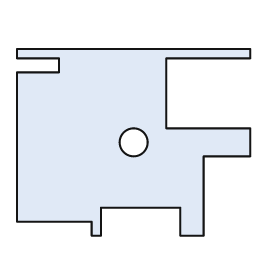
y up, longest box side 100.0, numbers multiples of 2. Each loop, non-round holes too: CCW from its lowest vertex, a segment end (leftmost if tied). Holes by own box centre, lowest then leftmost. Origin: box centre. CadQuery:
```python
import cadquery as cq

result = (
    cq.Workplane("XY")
    .moveTo(-18.0, -40.0)
    .lineTo(-14.0, -40.0)
    .lineTo(-14.0, -28.0)
    .lineTo(20.0, -28.0)
    .lineTo(20.0, -40.0)
    .lineTo(30.0, -40.0)
    .lineTo(30.0, -6.0)
    .lineTo(50.0, -6.0)
    .lineTo(50.0, 6.0)
    .lineTo(14.0, 6.0)
    .lineTo(14.0, 36.0)
    .lineTo(50.0, 36.0)
    .lineTo(50.0, 40.0)
    .lineTo(-50.0, 40.0)
    .lineTo(-50.0, 36.0)
    .lineTo(-32.0, 36.0)
    .lineTo(-32.0, 30.0)
    .lineTo(-50.0, 30.0)
    .lineTo(-50.0, -34.0)
    .lineTo(-18.0, -34.0)
    .close()
    .moveTo(0.0, 0.0)
    .circle(6.0)
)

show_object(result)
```